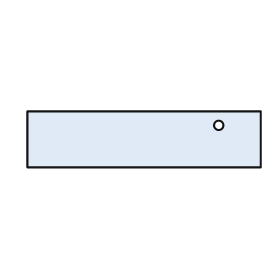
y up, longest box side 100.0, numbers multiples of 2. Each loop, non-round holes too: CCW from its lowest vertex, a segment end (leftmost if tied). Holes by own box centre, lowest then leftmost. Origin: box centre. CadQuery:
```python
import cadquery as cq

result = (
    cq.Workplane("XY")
    .moveTo(-50.0, -12.0)
    .lineTo(50.0, -12.0)
    .lineTo(50.0, 12.0)
    .lineTo(-50.0, 12.0)
    .close()
    .moveTo(32.0, 6.0)
    .circle(2.0)
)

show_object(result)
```